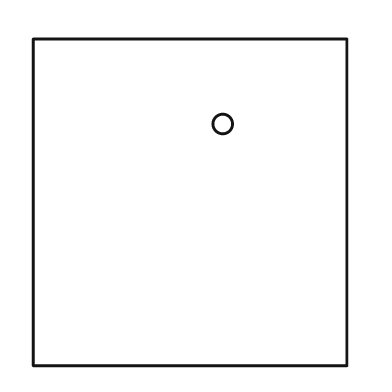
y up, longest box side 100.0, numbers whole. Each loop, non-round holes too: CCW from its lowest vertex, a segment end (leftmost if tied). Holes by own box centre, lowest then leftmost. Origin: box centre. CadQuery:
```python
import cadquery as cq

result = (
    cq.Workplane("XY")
    .moveTo(-48.0, -50.0)
    .lineTo(48.0, -50.0)
    .lineTo(48.0, 50.0)
    .lineTo(-48.0, 50.0)
    .close()
    .moveTo(10.0, 24.0)
    .circle(3.0)
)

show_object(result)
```